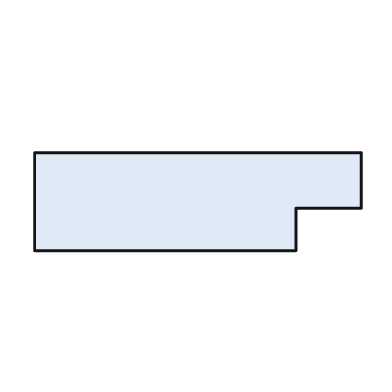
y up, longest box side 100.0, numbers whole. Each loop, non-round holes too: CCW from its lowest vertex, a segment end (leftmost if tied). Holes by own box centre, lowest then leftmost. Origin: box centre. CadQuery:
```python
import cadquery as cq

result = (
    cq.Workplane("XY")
    .moveTo(-50.0, -15.0)
    .lineTo(30.0, -15.0)
    .lineTo(30.0, -2.0)
    .lineTo(50.0, -2.0)
    .lineTo(50.0, 15.0)
    .lineTo(-50.0, 15.0)
    .close()
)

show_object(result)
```